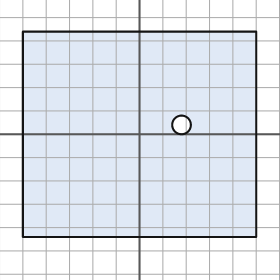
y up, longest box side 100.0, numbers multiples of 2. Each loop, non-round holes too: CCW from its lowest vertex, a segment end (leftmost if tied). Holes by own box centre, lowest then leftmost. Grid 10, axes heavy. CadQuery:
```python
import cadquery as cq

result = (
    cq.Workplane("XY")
    .moveTo(-50.0, -44.0)
    .lineTo(50.0, -44.0)
    .lineTo(50.0, 44.0)
    .lineTo(-50.0, 44.0)
    .close()
    .moveTo(18.0, 4.0)
    .circle(4.0)
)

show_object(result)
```